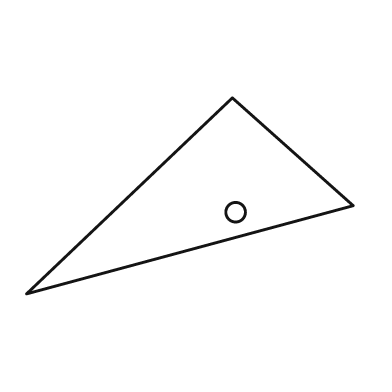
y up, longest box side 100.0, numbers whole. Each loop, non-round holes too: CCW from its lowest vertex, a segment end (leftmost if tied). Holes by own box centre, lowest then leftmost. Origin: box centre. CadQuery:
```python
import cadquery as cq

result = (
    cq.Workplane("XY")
    .moveTo(-50.0, -30.0)
    .lineTo(50.0, -3.0)
    .lineTo(13.0, 30.0)
    .close()
    .moveTo(14.0, -5.0)
    .circle(3.0)
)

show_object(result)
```